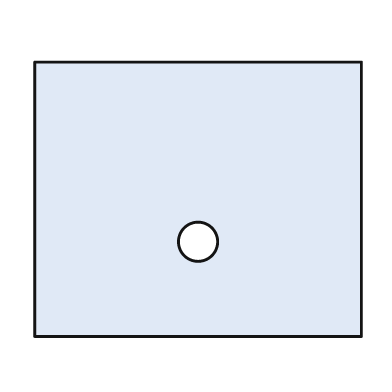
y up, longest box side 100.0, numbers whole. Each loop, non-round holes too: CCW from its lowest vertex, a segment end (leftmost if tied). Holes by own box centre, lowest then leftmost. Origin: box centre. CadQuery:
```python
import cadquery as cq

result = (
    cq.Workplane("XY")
    .moveTo(-50.0, -42.0)
    .lineTo(50.0, -42.0)
    .lineTo(50.0, 42.0)
    .lineTo(-50.0, 42.0)
    .close()
    .moveTo(0.0, -13.0)
    .circle(6.0)
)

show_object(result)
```